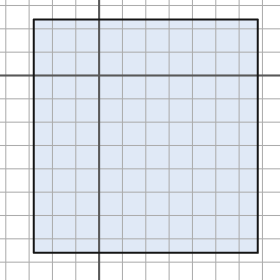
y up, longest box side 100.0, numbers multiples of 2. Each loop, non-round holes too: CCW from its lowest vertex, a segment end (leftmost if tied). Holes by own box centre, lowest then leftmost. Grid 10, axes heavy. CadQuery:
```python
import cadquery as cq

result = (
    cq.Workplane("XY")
    .moveTo(-28.0, -76.0)
    .lineTo(68.0, -76.0)
    .lineTo(68.0, 24.0)
    .lineTo(-28.0, 24.0)
    .close()
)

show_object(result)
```